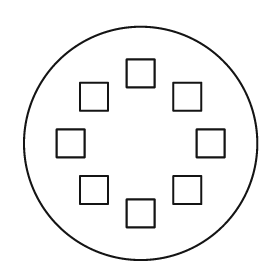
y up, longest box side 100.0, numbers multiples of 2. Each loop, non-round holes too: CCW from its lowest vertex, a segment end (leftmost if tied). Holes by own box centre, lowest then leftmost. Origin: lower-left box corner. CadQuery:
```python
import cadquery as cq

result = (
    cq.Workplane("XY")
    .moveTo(50.0, 50.0)
    .circle(50.0)
    .moveTo(44.0, 14.0)
    .lineTo(56.0, 14.0)
    .lineTo(56.0, 26.0)
    .lineTo(44.0, 26.0)
    .close()
    .moveTo(24.0, 24.0)
    .lineTo(36.0, 24.0)
    .lineTo(36.0, 36.0)
    .lineTo(24.0, 36.0)
    .close()
    .moveTo(64.0, 24.0)
    .lineTo(76.0, 24.0)
    .lineTo(76.0, 36.0)
    .lineTo(64.0, 36.0)
    .close()
    .moveTo(14.0, 44.0)
    .lineTo(26.0, 44.0)
    .lineTo(26.0, 56.0)
    .lineTo(14.0, 56.0)
    .close()
    .moveTo(74.0, 44.0)
    .lineTo(86.0, 44.0)
    .lineTo(86.0, 56.0)
    .lineTo(74.0, 56.0)
    .close()
    .moveTo(24.0, 64.0)
    .lineTo(36.0, 64.0)
    .lineTo(36.0, 76.0)
    .lineTo(24.0, 76.0)
    .close()
    .moveTo(64.0, 64.0)
    .lineTo(76.0, 64.0)
    .lineTo(76.0, 76.0)
    .lineTo(64.0, 76.0)
    .close()
    .moveTo(44.0, 74.0)
    .lineTo(56.0, 74.0)
    .lineTo(56.0, 86.0)
    .lineTo(44.0, 86.0)
    .close()
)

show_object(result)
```